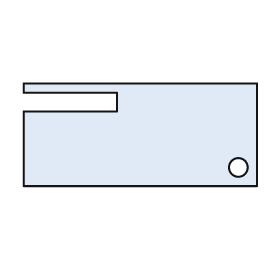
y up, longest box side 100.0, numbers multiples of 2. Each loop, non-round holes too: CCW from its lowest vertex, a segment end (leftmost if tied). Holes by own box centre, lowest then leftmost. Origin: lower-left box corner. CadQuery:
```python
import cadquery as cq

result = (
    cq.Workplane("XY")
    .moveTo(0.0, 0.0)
    .lineTo(100.0, 0.0)
    .lineTo(100.0, 44.0)
    .lineTo(0.0, 44.0)
    .lineTo(0.0, 40.0)
    .lineTo(40.0, 40.0)
    .lineTo(40.0, 32.0)
    .lineTo(0.0, 32.0)
    .close()
    .moveTo(92.0, 8.0)
    .circle(4.0)
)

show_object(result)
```